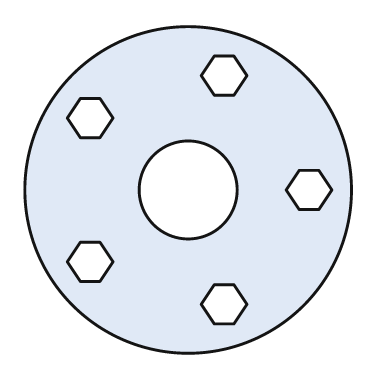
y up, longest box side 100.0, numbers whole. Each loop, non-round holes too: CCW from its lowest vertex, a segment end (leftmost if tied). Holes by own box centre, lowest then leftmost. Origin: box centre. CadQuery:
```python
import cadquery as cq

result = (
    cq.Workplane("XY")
    .moveTo(0.0, 0.0)
    .circle(50.0)
    .moveTo(8.0, -41.0)
    .lineTo(14.0, -41.0)
    .lineTo(18.0, -35.0)
    .lineTo(14.0, -29.0)
    .lineTo(8.0, -29.0)
    .lineTo(4.0, -35.0)
    .close()
    .moveTo(-33.0, -28.0)
    .lineTo(-27.0, -28.0)
    .lineTo(-23.0, -22.0)
    .lineTo(-27.0, -16.0)
    .lineTo(-33.0, -16.0)
    .lineTo(-37.0, -22.0)
    .close()
    .moveTo(0.0, 0.0)
    .circle(15.0)
    .moveTo(34.0, -6.0)
    .lineTo(40.0, -6.0)
    .lineTo(44.0, 0.0)
    .lineTo(40.0, 6.0)
    .lineTo(34.0, 6.0)
    .lineTo(30.0, 0.0)
    .close()
    .moveTo(-33.0, 16.0)
    .lineTo(-27.0, 16.0)
    .lineTo(-23.0, 22.0)
    .lineTo(-27.0, 28.0)
    .lineTo(-33.0, 28.0)
    .lineTo(-37.0, 22.0)
    .close()
    .moveTo(8.0, 29.0)
    .lineTo(14.0, 29.0)
    .lineTo(18.0, 35.0)
    .lineTo(14.0, 41.0)
    .lineTo(8.0, 41.0)
    .lineTo(4.0, 35.0)
    .close()
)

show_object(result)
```